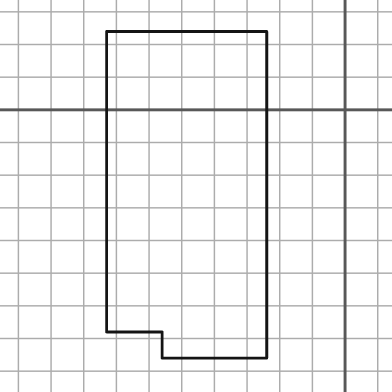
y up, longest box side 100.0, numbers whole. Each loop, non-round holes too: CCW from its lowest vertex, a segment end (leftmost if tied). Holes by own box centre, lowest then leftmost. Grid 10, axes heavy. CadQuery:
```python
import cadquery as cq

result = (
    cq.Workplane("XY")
    .moveTo(-56.0, -76.0)
    .lineTo(-24.0, -76.0)
    .lineTo(-24.0, 24.0)
    .lineTo(-73.0, 24.0)
    .lineTo(-73.0, -68.0)
    .lineTo(-56.0, -68.0)
    .close()
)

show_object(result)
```